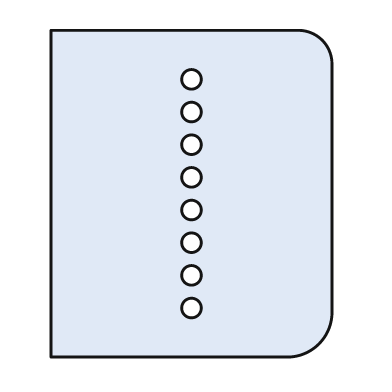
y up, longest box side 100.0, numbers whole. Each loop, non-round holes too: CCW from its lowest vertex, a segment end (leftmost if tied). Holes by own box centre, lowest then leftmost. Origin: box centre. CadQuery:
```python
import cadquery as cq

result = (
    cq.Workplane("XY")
    .moveTo(-43.0, -50.0)
    .lineTo(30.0, -50.0)
    .threePointArc((39.0, -46.0), (43.0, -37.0))
    .lineTo(43.0, 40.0)
    .threePointArc((40.0, 47.0), (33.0, 50.0))
    .lineTo(-43.0, 50.0)
    .close()
    .moveTo(0.0, -35.0)
    .circle(3.0)
    .moveTo(0.0, -25.0)
    .circle(3.0)
    .moveTo(0.0, -15.0)
    .circle(3.0)
    .moveTo(0.0, -5.0)
    .circle(3.0)
    .moveTo(0.0, 5.0)
    .circle(3.0)
    .moveTo(0.0, 15.0)
    .circle(3.0)
    .moveTo(0.0, 25.0)
    .circle(3.0)
    .moveTo(0.0, 35.0)
    .circle(3.0)
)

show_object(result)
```